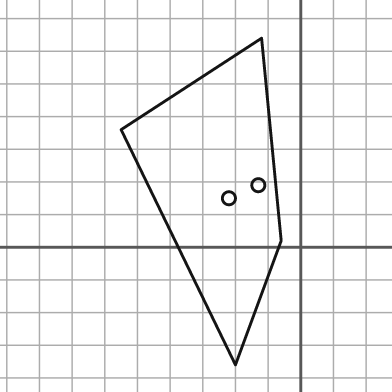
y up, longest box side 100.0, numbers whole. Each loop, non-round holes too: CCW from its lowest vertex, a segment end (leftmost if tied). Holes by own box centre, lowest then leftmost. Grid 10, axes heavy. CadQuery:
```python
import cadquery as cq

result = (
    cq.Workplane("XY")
    .moveTo(-20.0, -36.0)
    .lineTo(-6.0, 2.0)
    .lineTo(-12.0, 64.0)
    .lineTo(-55.0, 36.0)
    .close()
    .moveTo(-22.0, 15.0)
    .circle(2.0)
    .moveTo(-13.0, 19.0)
    .circle(2.0)
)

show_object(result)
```